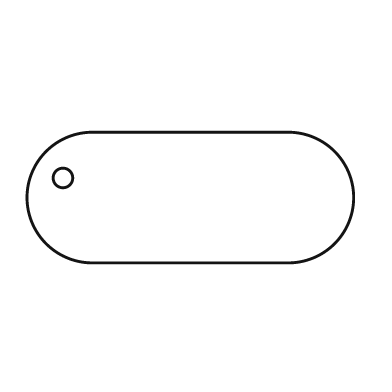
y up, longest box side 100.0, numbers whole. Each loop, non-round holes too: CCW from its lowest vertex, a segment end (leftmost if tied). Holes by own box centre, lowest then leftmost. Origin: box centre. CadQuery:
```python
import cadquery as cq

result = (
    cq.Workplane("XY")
    .moveTo(-30.0, -20.0)
    .lineTo(30.0, -20.0)
    .threePointArc((50.0, 0.0), (30.0, 20.0))
    .lineTo(-30.0, 20.0)
    .threePointArc((-50.0, 0.0), (-30.0, -20.0))
    .close()
    .moveTo(-39.0, 6.0)
    .circle(3.0)
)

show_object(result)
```